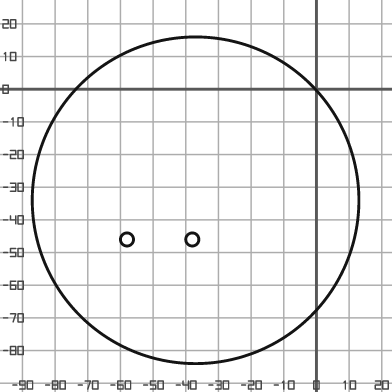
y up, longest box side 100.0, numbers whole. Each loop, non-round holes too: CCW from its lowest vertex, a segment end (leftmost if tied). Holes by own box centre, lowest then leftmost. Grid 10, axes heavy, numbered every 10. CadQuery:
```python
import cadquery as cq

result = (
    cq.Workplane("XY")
    .moveTo(-37.0, -34.0)
    .circle(50.0)
    .moveTo(-58.0, -46.0)
    .circle(2.0)
    .moveTo(-38.0, -46.0)
    .circle(2.0)
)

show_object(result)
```